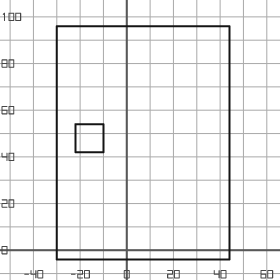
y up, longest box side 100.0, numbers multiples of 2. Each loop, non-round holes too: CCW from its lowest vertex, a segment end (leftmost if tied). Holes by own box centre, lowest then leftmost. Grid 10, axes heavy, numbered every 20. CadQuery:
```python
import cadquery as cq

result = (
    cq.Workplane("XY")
    .moveTo(-30.0, -4.0)
    .lineTo(44.0, -4.0)
    .lineTo(44.0, 96.0)
    .lineTo(-30.0, 96.0)
    .close()
    .moveTo(-22.0, 42.0)
    .lineTo(-10.0, 42.0)
    .lineTo(-10.0, 54.0)
    .lineTo(-22.0, 54.0)
    .close()
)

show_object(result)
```